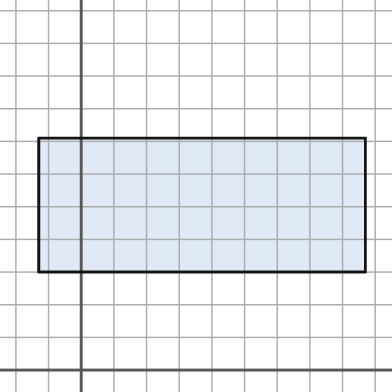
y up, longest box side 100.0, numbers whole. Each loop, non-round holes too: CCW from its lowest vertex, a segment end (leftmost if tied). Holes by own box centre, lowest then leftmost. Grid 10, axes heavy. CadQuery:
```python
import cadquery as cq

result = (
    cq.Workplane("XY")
    .moveTo(-13.0, 30.0)
    .lineTo(87.0, 30.0)
    .lineTo(87.0, 71.0)
    .lineTo(-13.0, 71.0)
    .close()
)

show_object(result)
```